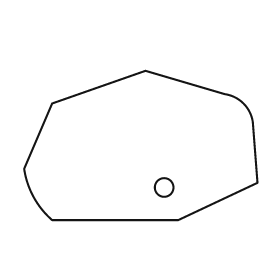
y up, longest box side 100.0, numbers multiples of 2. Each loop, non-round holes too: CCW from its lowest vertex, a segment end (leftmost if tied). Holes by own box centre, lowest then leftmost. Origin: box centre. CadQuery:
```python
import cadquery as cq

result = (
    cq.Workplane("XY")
    .moveTo(-38.0, -32.0)
    .lineTo(16.0, -32.0)
    .lineTo(50.0, -16.0)
    .lineTo(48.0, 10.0)
    .threePointArc((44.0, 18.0), (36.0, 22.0))
    .lineTo(2.0, 32.0)
    .lineTo(-38.0, 18.0)
    .lineTo(-50.0, -10.0)
    .threePointArc((-46.0, -22.0), (-38.0, -32.0))
    .close()
    .moveTo(10.0, -18.0)
    .circle(4.0)
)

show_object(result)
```